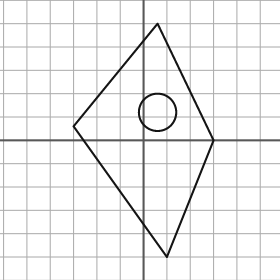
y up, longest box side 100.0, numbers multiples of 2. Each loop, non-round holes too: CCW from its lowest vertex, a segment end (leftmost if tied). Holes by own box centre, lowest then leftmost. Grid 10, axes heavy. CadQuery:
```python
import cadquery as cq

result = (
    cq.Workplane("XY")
    .moveTo(10.0, -50.0)
    .lineTo(30.0, 0.0)
    .lineTo(6.0, 50.0)
    .lineTo(-30.0, 6.0)
    .close()
    .moveTo(6.0, 12.0)
    .circle(8.0)
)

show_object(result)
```